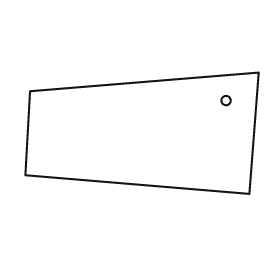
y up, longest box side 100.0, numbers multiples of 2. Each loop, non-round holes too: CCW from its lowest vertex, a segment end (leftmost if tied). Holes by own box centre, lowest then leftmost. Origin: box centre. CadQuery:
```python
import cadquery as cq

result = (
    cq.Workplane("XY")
    .moveTo(46.0, -26.0)
    .lineTo(50.0, 26.0)
    .lineTo(-48.0, 18.0)
    .lineTo(-50.0, -18.0)
    .close()
    .moveTo(36.0, 14.0)
    .circle(2.0)
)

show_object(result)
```